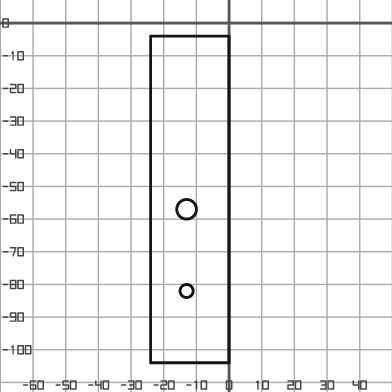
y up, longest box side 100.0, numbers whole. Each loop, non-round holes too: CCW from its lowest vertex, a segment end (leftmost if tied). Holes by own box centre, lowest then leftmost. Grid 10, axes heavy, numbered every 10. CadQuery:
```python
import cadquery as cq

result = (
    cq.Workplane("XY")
    .moveTo(-24.0, -104.0)
    .lineTo(0.0, -104.0)
    .lineTo(0.0, -4.0)
    .lineTo(-24.0, -4.0)
    .close()
    .moveTo(-13.0, -82.0)
    .circle(2.0)
    .moveTo(-13.0, -57.0)
    .circle(3.0)
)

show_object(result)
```